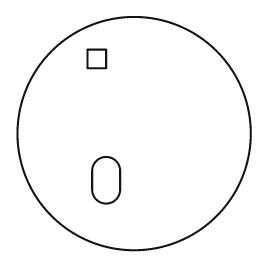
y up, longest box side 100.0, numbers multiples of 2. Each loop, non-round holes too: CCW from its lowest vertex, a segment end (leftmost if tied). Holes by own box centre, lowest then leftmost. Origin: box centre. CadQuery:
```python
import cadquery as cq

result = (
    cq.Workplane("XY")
    .moveTo(0.0, 0.0)
    .circle(50.0)
    .moveTo(-18.0, -24.0)
    .threePointArc((-12.0, -30.0), (-6.0, -24.0))
    .lineTo(-6.0, -16.0)
    .threePointArc((-12.0, -10.0), (-18.0, -16.0))
    .close()
    .moveTo(-20.0, 28.0)
    .lineTo(-12.0, 28.0)
    .lineTo(-12.0, 36.0)
    .lineTo(-20.0, 36.0)
    .close()
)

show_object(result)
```